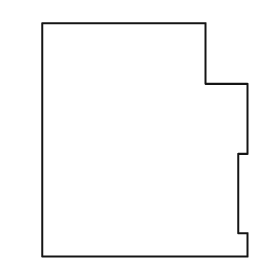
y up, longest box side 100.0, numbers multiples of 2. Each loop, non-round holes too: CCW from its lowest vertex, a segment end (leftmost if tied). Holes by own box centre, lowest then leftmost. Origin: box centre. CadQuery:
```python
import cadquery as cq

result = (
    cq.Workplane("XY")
    .moveTo(-44.0, -50.0)
    .lineTo(44.0, -50.0)
    .lineTo(44.0, -40.0)
    .lineTo(40.0, -40.0)
    .lineTo(40.0, -6.0)
    .lineTo(44.0, -6.0)
    .lineTo(44.0, 24.0)
    .lineTo(26.0, 24.0)
    .lineTo(26.0, 50.0)
    .lineTo(-44.0, 50.0)
    .close()
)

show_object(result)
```